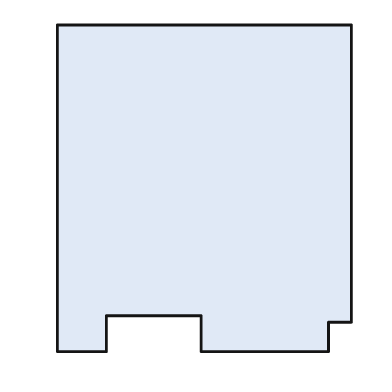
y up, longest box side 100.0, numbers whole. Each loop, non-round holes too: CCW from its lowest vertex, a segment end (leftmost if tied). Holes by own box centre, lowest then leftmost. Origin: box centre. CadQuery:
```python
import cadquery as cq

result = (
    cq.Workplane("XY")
    .moveTo(-45.0, -50.0)
    .lineTo(-30.0, -50.0)
    .lineTo(-30.0, -39.0)
    .lineTo(-1.0, -39.0)
    .lineTo(-1.0, -50.0)
    .lineTo(38.0, -50.0)
    .lineTo(38.0, -41.0)
    .lineTo(45.0, -41.0)
    .lineTo(45.0, 50.0)
    .lineTo(-45.0, 50.0)
    .close()
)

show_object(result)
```